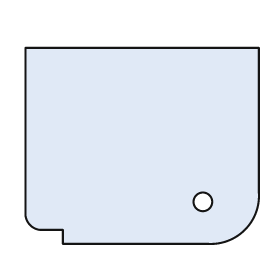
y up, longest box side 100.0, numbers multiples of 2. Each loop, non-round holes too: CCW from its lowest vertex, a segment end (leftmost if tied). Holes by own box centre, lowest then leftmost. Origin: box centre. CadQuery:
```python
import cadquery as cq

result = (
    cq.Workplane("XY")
    .moveTo(-34.0, -42.0)
    .lineTo(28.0, -42.0)
    .threePointArc((44.0, -36.0), (50.0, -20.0))
    .lineTo(50.0, 42.0)
    .lineTo(-50.0, 42.0)
    .lineTo(-50.0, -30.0)
    .threePointArc((-48.0, -34.0), (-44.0, -36.0))
    .lineTo(-34.0, -36.0)
    .close()
    .moveTo(26.0, -24.0)
    .circle(4.0)
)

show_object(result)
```